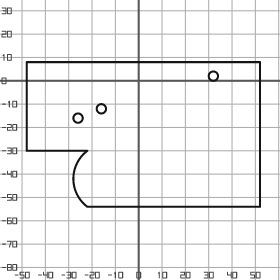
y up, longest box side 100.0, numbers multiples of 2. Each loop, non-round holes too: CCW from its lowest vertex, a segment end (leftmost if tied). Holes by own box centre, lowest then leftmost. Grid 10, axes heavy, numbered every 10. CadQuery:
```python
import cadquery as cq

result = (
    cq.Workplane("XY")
    .moveTo(-22.0, -54.0)
    .lineTo(52.0, -54.0)
    .lineTo(52.0, 8.0)
    .lineTo(-48.0, 8.0)
    .lineTo(-48.0, -30.0)
    .lineTo(-22.0, -30.0)
    .threePointArc((-28.0, -42.0), (-22.0, -54.0))
    .close()
    .moveTo(-26.0, -16.0)
    .circle(2.0)
    .moveTo(-16.0, -12.0)
    .circle(2.0)
    .moveTo(32.0, 2.0)
    .circle(2.0)
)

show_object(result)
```